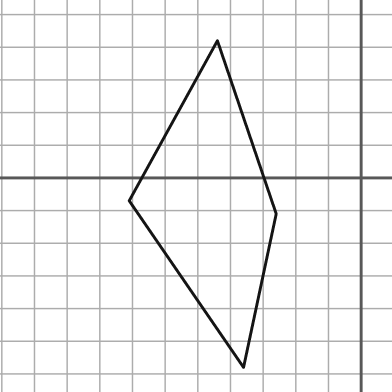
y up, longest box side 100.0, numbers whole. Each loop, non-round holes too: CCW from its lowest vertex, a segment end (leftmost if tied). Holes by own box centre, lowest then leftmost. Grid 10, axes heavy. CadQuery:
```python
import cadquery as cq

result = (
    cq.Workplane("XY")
    .moveTo(-36.0, -58.0)
    .lineTo(-26.0, -11.0)
    .lineTo(-44.0, 42.0)
    .lineTo(-71.0, -7.0)
    .close()
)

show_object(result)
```